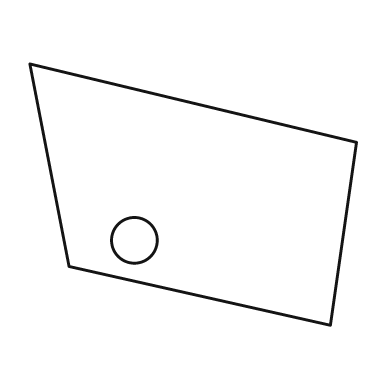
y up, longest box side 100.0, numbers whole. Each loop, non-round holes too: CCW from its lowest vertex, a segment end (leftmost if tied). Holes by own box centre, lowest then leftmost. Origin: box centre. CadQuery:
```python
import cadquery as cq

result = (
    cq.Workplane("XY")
    .moveTo(42.0, -40.0)
    .lineTo(50.0, 16.0)
    .lineTo(-50.0, 40.0)
    .lineTo(-38.0, -22.0)
    .close()
    .moveTo(-18.0, -14.0)
    .circle(7.0)
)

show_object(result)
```